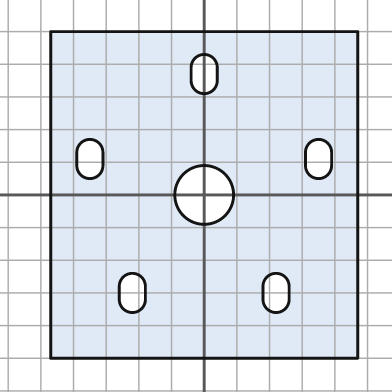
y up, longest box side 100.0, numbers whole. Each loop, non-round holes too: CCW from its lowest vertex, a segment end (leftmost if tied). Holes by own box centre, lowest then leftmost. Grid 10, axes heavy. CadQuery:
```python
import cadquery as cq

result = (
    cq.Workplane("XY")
    .moveTo(-47.0, -50.0)
    .lineTo(47.0, -50.0)
    .lineTo(47.0, 50.0)
    .lineTo(-47.0, 50.0)
    .close()
    .moveTo(-26.0, -32.0)
    .threePointArc((-22.0, -36.0), (-18.0, -32.0))
    .lineTo(-18.0, -28.0)
    .threePointArc((-22.0, -24.0), (-26.0, -28.0))
    .close()
    .moveTo(18.0, -32.0)
    .threePointArc((22.0, -36.0), (26.0, -32.0))
    .lineTo(26.0, -28.0)
    .threePointArc((22.0, -24.0), (18.0, -28.0))
    .close()
    .moveTo(0.0, 0.0)
    .circle(9.0)
    .moveTo(-39.0, 9.0)
    .threePointArc((-35.0, 5.0), (-31.0, 9.0))
    .lineTo(-31.0, 13.0)
    .threePointArc((-35.0, 17.0), (-39.0, 13.0))
    .close()
    .moveTo(31.0, 9.0)
    .threePointArc((35.0, 5.0), (39.0, 9.0))
    .lineTo(39.0, 13.0)
    .threePointArc((35.0, 17.0), (31.0, 13.0))
    .close()
    .moveTo(-4.0, 35.0)
    .threePointArc((0.0, 31.0), (4.0, 35.0))
    .lineTo(4.0, 39.0)
    .threePointArc((0.0, 43.0), (-4.0, 39.0))
    .close()
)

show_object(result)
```